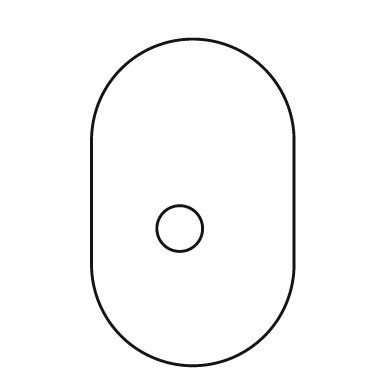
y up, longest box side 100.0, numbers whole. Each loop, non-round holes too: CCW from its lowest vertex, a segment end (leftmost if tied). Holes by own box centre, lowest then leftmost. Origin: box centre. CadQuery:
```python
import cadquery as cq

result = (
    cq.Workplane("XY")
    .moveTo(-31.0, -19.0)
    .threePointArc((0.0, -50.0), (31.0, -19.0))
    .lineTo(31.0, 19.0)
    .threePointArc((0.0, 50.0), (-31.0, 19.0))
    .close()
    .moveTo(-4.0, -8.0)
    .circle(7.0)
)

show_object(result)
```